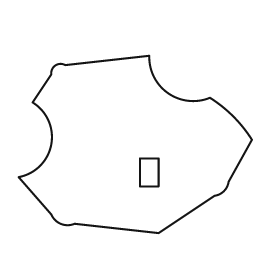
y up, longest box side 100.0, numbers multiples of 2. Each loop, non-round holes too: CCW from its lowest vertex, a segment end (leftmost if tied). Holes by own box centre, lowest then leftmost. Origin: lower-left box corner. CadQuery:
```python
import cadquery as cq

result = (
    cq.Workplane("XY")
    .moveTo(60.0, 0.0)
    .lineTo(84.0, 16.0)
    .threePointArc((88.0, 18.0), (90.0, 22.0))
    .lineTo(100.0, 40.0)
    .threePointArc((92.0, 50.0), (82.0, 58.0))
    .threePointArc((64.0, 60.0), (56.0, 76.0))
    .lineTo(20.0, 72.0)
    .threePointArc((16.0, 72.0), (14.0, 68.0))
    .lineTo(6.0, 56.0)
    .threePointArc((14.0, 38.0), (0.0, 24.0))
    .lineTo(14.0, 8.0)
    .threePointArc((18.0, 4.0), (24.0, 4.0))
    .close()
    .moveTo(52.0, 20.0)
    .lineTo(60.0, 20.0)
    .lineTo(60.0, 32.0)
    .lineTo(52.0, 32.0)
    .close()
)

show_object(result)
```